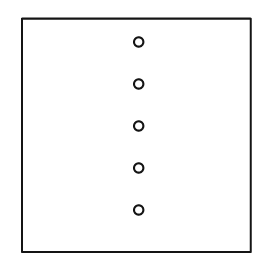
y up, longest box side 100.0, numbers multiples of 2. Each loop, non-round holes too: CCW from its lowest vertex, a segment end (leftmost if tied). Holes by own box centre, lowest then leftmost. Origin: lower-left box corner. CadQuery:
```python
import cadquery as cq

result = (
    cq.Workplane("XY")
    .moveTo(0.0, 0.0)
    .lineTo(98.0, 0.0)
    .lineTo(98.0, 100.0)
    .lineTo(0.0, 100.0)
    .close()
    .moveTo(50.0, 18.0)
    .circle(2.0)
    .moveTo(50.0, 36.0)
    .circle(2.0)
    .moveTo(50.0, 54.0)
    .circle(2.0)
    .moveTo(50.0, 72.0)
    .circle(2.0)
    .moveTo(50.0, 90.0)
    .circle(2.0)
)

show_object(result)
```